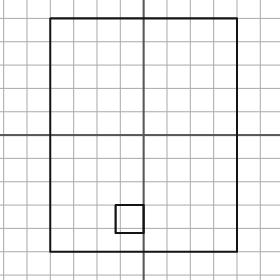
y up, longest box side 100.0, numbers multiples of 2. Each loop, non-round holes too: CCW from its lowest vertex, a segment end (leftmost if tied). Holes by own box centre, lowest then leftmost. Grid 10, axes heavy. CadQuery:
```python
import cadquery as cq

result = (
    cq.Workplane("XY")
    .moveTo(-40.0, -50.0)
    .lineTo(40.0, -50.0)
    .lineTo(40.0, 50.0)
    .lineTo(-40.0, 50.0)
    .close()
    .moveTo(-12.0, -42.0)
    .lineTo(0.0, -42.0)
    .lineTo(0.0, -30.0)
    .lineTo(-12.0, -30.0)
    .close()
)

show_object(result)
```